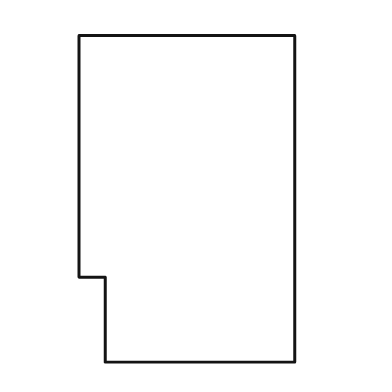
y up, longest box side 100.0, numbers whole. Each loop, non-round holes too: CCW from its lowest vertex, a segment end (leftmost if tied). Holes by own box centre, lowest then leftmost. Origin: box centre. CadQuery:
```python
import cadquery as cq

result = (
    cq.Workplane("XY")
    .moveTo(-25.0, -50.0)
    .lineTo(33.0, -50.0)
    .lineTo(33.0, 50.0)
    .lineTo(-33.0, 50.0)
    .lineTo(-33.0, -24.0)
    .lineTo(-25.0, -24.0)
    .close()
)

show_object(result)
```